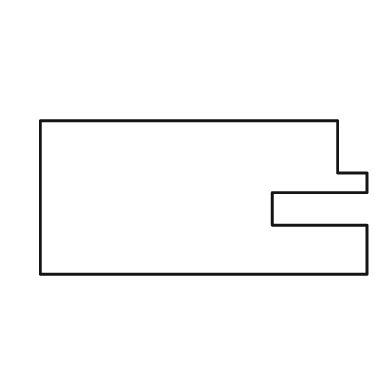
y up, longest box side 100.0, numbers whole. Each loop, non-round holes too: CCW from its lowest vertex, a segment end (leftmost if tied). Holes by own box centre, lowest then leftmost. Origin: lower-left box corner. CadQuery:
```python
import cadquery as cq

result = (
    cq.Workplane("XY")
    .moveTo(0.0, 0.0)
    .lineTo(100.0, 0.0)
    .lineTo(100.0, 15.0)
    .lineTo(71.0, 15.0)
    .lineTo(71.0, 25.0)
    .lineTo(100.0, 25.0)
    .lineTo(100.0, 31.0)
    .lineTo(91.0, 31.0)
    .lineTo(91.0, 47.0)
    .lineTo(0.0, 47.0)
    .close()
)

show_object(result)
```